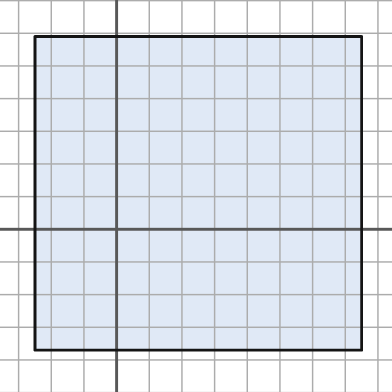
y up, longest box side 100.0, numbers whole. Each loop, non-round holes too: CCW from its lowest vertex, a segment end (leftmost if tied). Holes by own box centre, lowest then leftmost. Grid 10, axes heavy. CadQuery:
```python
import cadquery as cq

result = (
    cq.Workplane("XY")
    .moveTo(-25.0, -37.0)
    .lineTo(75.0, -37.0)
    .lineTo(75.0, 59.0)
    .lineTo(-25.0, 59.0)
    .close()
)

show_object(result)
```